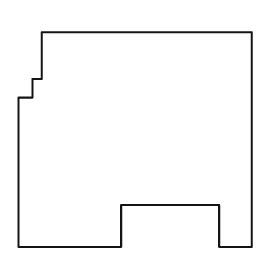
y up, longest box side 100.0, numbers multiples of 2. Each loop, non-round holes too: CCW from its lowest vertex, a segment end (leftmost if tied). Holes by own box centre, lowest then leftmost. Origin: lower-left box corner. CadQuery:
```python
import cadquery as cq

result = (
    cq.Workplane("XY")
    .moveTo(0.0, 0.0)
    .lineTo(44.0, 0.0)
    .lineTo(44.0, 18.0)
    .lineTo(86.0, 18.0)
    .lineTo(86.0, 0.0)
    .lineTo(100.0, 0.0)
    .lineTo(100.0, 92.0)
    .lineTo(10.0, 92.0)
    .lineTo(10.0, 72.0)
    .lineTo(6.0, 72.0)
    .lineTo(6.0, 64.0)
    .lineTo(0.0, 64.0)
    .close()
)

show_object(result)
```